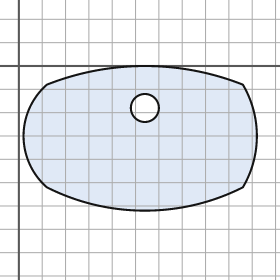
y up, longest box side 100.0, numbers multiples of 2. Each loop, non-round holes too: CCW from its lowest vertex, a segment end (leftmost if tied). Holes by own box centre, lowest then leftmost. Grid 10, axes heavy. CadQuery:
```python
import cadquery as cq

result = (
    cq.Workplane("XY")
    .moveTo(12.0, -52.0)
    .threePointArc((54.0, -62.0), (96.0, -52.0))
    .threePointArc((102.0, -30.0), (96.0, -8.0))
    .threePointArc((54.0, 0.0), (12.0, -8.0))
    .threePointArc((2.0, -30.0), (12.0, -52.0))
    .close()
    .moveTo(54.0, -18.0)
    .circle(6.0)
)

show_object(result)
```